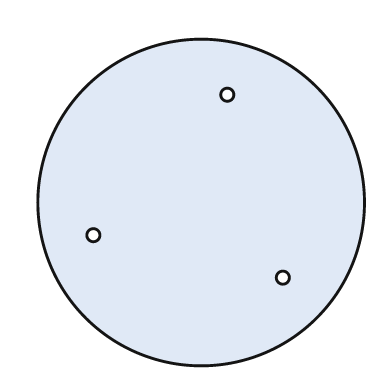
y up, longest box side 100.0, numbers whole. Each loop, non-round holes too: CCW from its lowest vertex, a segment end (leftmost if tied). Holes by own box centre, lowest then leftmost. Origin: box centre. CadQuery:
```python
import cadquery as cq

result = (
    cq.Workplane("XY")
    .moveTo(0.0, 0.0)
    .circle(50.0)
    .moveTo(25.0, -23.0)
    .circle(2.0)
    .moveTo(-33.0, -10.0)
    .circle(2.0)
    .moveTo(8.0, 33.0)
    .circle(2.0)
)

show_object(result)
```